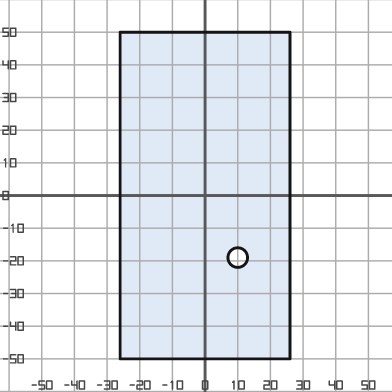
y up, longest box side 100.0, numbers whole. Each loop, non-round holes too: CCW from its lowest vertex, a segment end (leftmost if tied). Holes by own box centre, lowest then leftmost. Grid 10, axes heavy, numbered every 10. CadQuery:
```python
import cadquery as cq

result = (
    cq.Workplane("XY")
    .moveTo(-26.0, -50.0)
    .lineTo(26.0, -50.0)
    .lineTo(26.0, 50.0)
    .lineTo(-26.0, 50.0)
    .close()
    .moveTo(10.0, -19.0)
    .circle(3.0)
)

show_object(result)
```